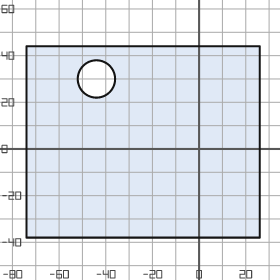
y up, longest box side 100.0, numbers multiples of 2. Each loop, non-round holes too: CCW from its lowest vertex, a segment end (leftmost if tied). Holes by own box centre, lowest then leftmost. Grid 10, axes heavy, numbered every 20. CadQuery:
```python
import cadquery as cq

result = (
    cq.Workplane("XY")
    .moveTo(-74.0, -38.0)
    .lineTo(26.0, -38.0)
    .lineTo(26.0, 44.0)
    .lineTo(-74.0, 44.0)
    .close()
    .moveTo(-44.0, 30.0)
    .circle(8.0)
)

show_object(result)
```